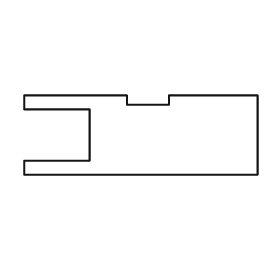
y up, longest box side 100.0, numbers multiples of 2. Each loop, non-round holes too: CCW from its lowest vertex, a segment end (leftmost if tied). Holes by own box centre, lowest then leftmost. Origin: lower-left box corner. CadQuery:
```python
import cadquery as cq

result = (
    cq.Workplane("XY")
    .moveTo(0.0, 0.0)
    .lineTo(100.0, 0.0)
    .lineTo(100.0, 34.0)
    .lineTo(62.0, 34.0)
    .lineTo(62.0, 30.0)
    .lineTo(44.0, 30.0)
    .lineTo(44.0, 34.0)
    .lineTo(0.0, 34.0)
    .lineTo(0.0, 28.0)
    .lineTo(28.0, 28.0)
    .lineTo(28.0, 6.0)
    .lineTo(0.0, 6.0)
    .close()
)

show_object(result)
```